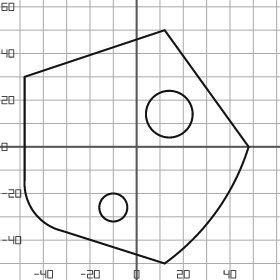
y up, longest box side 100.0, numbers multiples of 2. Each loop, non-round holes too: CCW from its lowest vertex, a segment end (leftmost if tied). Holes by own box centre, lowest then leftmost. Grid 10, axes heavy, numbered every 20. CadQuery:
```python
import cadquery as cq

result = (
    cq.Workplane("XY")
    .moveTo(12.0, -50.0)
    .threePointArc((34.0, -28.0), (48.0, 0.0))
    .lineTo(12.0, 50.0)
    .lineTo(-48.0, 30.0)
    .lineTo(-48.0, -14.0)
    .threePointArc((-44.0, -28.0), (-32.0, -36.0))
    .close()
    .moveTo(-10.0, -26.0)
    .circle(6.0)
    .moveTo(14.0, 14.0)
    .circle(10.0)
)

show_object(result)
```